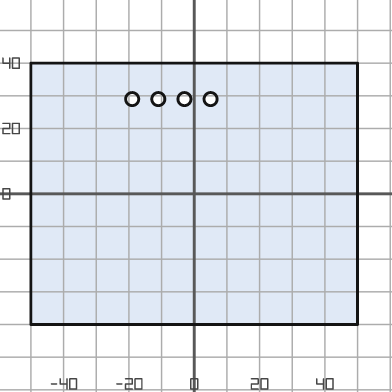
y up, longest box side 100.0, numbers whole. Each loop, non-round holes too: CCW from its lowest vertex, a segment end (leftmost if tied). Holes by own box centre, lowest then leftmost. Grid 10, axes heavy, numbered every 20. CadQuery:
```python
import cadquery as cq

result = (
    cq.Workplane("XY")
    .moveTo(-50.0, -40.0)
    .lineTo(50.0, -40.0)
    .lineTo(50.0, 40.0)
    .lineTo(-50.0, 40.0)
    .close()
    .moveTo(-19.0, 29.0)
    .circle(2.0)
    .moveTo(-11.0, 29.0)
    .circle(2.0)
    .moveTo(-3.0, 29.0)
    .circle(2.0)
    .moveTo(5.0, 29.0)
    .circle(2.0)
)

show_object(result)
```